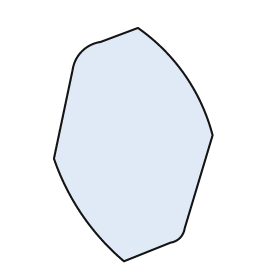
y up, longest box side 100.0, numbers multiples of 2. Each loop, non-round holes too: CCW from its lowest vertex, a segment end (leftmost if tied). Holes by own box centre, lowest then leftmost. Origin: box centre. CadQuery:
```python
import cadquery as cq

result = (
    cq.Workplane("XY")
    .moveTo(-4.0, -50.0)
    .lineTo(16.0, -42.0)
    .threePointArc((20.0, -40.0), (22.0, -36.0))
    .lineTo(34.0, 4.0)
    .threePointArc((22.0, 30.0), (2.0, 50.0))
    .lineTo(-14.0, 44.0)
    .threePointArc((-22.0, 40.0), (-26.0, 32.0))
    .lineTo(-34.0, -6.0)
    .threePointArc((-22.0, -30.0), (-4.0, -50.0))
    .close()
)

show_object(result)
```